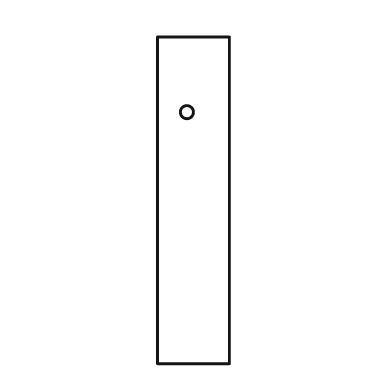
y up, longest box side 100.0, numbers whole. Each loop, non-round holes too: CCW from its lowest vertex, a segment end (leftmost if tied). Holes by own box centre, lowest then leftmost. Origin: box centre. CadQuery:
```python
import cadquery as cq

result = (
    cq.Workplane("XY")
    .moveTo(-11.0, -50.0)
    .lineTo(11.0, -50.0)
    .lineTo(11.0, 50.0)
    .lineTo(-11.0, 50.0)
    .close()
    .moveTo(-2.0, 27.0)
    .circle(2.0)
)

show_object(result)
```